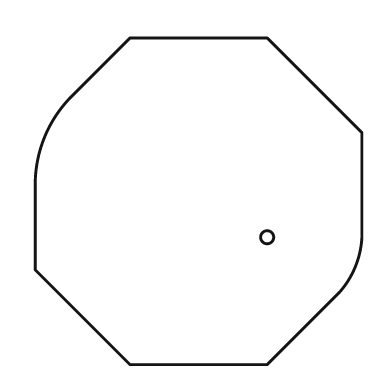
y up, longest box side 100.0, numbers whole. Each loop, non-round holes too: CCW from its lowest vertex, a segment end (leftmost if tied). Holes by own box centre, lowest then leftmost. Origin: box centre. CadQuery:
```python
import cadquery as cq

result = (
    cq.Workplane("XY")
    .moveTo(-21.0, -50.0)
    .lineTo(21.0, -50.0)
    .lineTo(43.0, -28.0)
    .threePointArc((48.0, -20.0), (50.0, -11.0))
    .lineTo(50.0, 21.0)
    .lineTo(21.0, 50.0)
    .lineTo(-21.0, 50.0)
    .lineTo(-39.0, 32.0)
    .threePointArc((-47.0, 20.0), (-50.0, 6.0))
    .lineTo(-50.0, -21.0)
    .close()
    .moveTo(21.0, -11.0)
    .circle(2.0)
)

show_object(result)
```